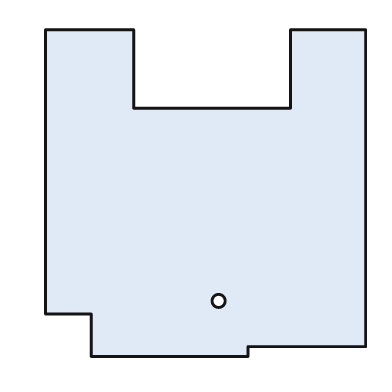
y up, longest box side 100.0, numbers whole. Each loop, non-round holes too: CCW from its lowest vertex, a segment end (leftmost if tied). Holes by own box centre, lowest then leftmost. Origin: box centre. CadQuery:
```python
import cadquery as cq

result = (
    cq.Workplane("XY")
    .moveTo(-35.0, -50.0)
    .lineTo(13.0, -50.0)
    .lineTo(13.0, -47.0)
    .lineTo(49.0, -47.0)
    .lineTo(49.0, 50.0)
    .lineTo(26.0, 50.0)
    .lineTo(26.0, 26.0)
    .lineTo(-22.0, 26.0)
    .lineTo(-22.0, 50.0)
    .lineTo(-49.0, 50.0)
    .lineTo(-49.0, -37.0)
    .lineTo(-35.0, -37.0)
    .close()
    .moveTo(4.0, -33.0)
    .circle(2.0)
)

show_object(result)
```